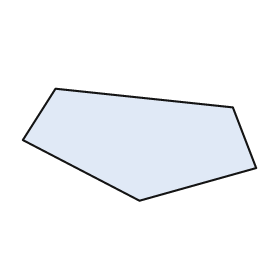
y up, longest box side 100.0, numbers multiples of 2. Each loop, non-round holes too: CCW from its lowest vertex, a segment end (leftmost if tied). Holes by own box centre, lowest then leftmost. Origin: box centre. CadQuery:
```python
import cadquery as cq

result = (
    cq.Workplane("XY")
    .moveTo(0.0, -24.0)
    .lineTo(50.0, -10.0)
    .lineTo(40.0, 16.0)
    .lineTo(-36.0, 24.0)
    .lineTo(-50.0, 2.0)
    .close()
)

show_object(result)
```